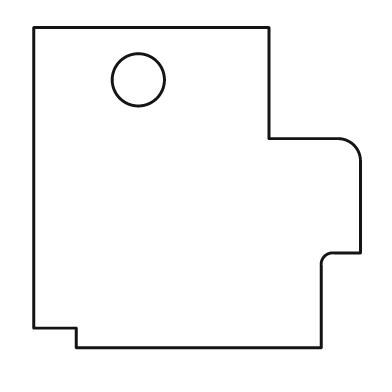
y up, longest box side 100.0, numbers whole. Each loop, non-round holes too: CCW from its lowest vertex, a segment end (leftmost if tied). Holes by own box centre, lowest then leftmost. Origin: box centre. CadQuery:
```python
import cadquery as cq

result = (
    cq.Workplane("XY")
    .moveTo(-37.0, -49.0)
    .lineTo(38.0, -49.0)
    .lineTo(38.0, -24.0)
    .threePointArc((39.0, -21.0), (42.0, -20.0))
    .lineTo(50.0, -20.0)
    .lineTo(50.0, 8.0)
    .threePointArc((48.0, 13.0), (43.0, 15.0))
    .lineTo(22.0, 15.0)
    .lineTo(22.0, 49.0)
    .lineTo(-50.0, 49.0)
    .lineTo(-50.0, -43.0)
    .lineTo(-37.0, -43.0)
    .close()
    .moveTo(-18.0, 33.0)
    .circle(8.0)
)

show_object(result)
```